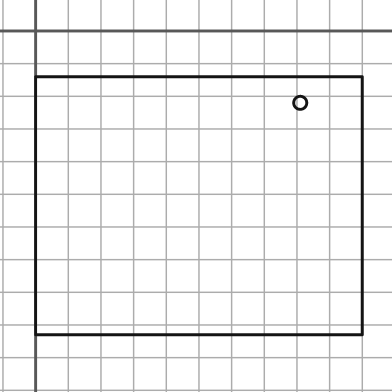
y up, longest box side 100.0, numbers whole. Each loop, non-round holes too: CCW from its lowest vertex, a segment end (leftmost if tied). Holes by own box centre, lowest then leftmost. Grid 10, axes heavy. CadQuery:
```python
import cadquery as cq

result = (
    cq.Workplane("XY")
    .moveTo(0.0, -93.0)
    .lineTo(100.0, -93.0)
    .lineTo(100.0, -14.0)
    .lineTo(0.0, -14.0)
    .close()
    .moveTo(81.0, -22.0)
    .circle(2.0)
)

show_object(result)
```